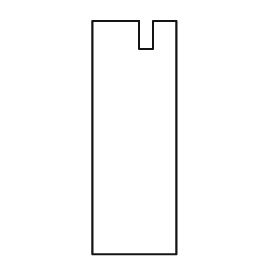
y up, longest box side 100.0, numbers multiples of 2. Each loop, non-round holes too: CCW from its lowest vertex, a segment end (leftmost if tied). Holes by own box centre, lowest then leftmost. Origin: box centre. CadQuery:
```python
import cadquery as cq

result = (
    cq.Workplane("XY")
    .moveTo(-18.0, -50.0)
    .lineTo(18.0, -50.0)
    .lineTo(18.0, 50.0)
    .lineTo(8.0, 50.0)
    .lineTo(8.0, 38.0)
    .lineTo(2.0, 38.0)
    .lineTo(2.0, 50.0)
    .lineTo(-18.0, 50.0)
    .close()
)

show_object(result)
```